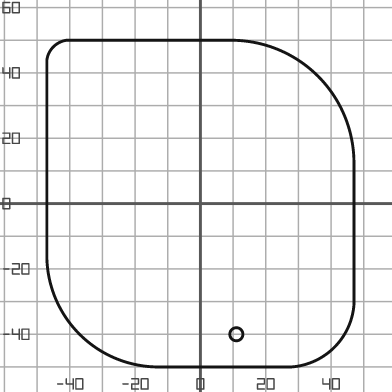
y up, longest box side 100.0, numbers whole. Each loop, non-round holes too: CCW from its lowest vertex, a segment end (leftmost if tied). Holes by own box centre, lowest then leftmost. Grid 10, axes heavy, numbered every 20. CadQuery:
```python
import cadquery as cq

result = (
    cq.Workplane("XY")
    .moveTo(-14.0, -50.0)
    .lineTo(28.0, -50.0)
    .threePointArc((41.0, -44.0), (47.0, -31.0))
    .lineTo(47.0, 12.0)
    .threePointArc((36.0, 39.0), (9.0, 50.0))
    .lineTo(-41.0, 50.0)
    .threePointArc((-45.0, 48.0), (-47.0, 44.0))
    .lineTo(-47.0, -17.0)
    .threePointArc((-37.0, -40.0), (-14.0, -50.0))
    .close()
    .moveTo(11.0, -40.0)
    .circle(2.0)
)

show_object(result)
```